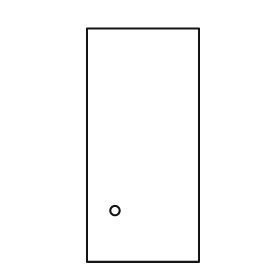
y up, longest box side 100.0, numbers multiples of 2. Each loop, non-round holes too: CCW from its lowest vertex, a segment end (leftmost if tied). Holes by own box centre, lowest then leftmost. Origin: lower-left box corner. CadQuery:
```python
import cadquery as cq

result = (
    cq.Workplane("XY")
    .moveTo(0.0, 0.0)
    .lineTo(48.0, 0.0)
    .lineTo(48.0, 100.0)
    .lineTo(0.0, 100.0)
    .close()
    .moveTo(12.0, 22.0)
    .circle(2.0)
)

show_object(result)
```